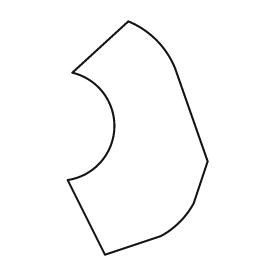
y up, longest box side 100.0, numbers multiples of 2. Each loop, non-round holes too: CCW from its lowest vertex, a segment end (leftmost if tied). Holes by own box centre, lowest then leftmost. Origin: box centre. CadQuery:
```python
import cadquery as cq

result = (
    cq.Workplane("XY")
    .moveTo(-14.0, -50.0)
    .lineTo(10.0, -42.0)
    .threePointArc((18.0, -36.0), (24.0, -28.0))
    .lineTo(30.0, -10.0)
    .lineTo(16.0, 30.0)
    .threePointArc((8.0, 42.0), (-4.0, 50.0))
    .lineTo(-28.0, 28.0)
    .threePointArc((-10.0, 4.0), (-30.0, -18.0))
    .close()
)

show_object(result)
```